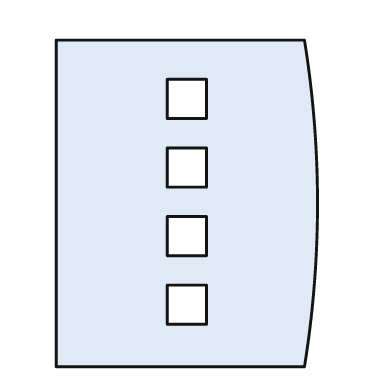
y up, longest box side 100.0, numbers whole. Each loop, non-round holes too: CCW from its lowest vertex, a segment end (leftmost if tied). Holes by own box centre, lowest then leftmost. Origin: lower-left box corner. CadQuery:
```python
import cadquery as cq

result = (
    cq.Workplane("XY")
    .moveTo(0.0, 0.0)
    .lineTo(76.0, 0.0)
    .threePointArc((80.0, 50.0), (76.0, 100.0))
    .lineTo(0.0, 100.0)
    .close()
    .moveTo(34.0, 13.0)
    .lineTo(46.0, 13.0)
    .lineTo(46.0, 25.0)
    .lineTo(34.0, 25.0)
    .close()
    .moveTo(34.0, 34.0)
    .lineTo(46.0, 34.0)
    .lineTo(46.0, 46.0)
    .lineTo(34.0, 46.0)
    .close()
    .moveTo(34.0, 55.0)
    .lineTo(46.0, 55.0)
    .lineTo(46.0, 67.0)
    .lineTo(34.0, 67.0)
    .close()
    .moveTo(34.0, 76.0)
    .lineTo(46.0, 76.0)
    .lineTo(46.0, 88.0)
    .lineTo(34.0, 88.0)
    .close()
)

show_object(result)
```